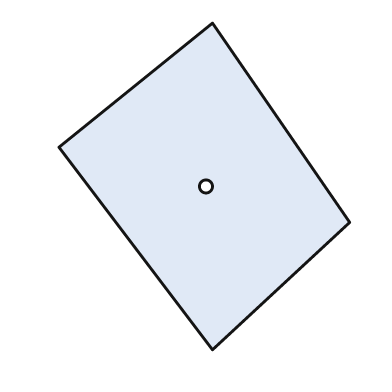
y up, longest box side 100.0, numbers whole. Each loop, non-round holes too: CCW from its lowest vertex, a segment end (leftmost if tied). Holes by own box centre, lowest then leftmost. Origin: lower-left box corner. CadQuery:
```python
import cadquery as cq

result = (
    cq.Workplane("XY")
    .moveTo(47.0, 0.0)
    .lineTo(89.0, 39.0)
    .lineTo(47.0, 100.0)
    .lineTo(0.0, 62.0)
    .close()
    .moveTo(45.0, 50.0)
    .circle(2.0)
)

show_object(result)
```